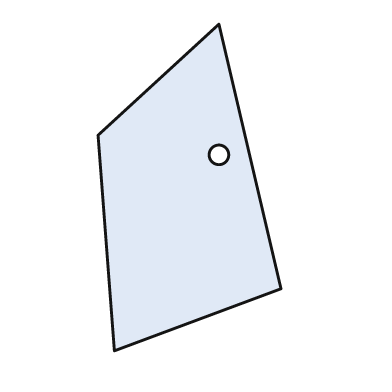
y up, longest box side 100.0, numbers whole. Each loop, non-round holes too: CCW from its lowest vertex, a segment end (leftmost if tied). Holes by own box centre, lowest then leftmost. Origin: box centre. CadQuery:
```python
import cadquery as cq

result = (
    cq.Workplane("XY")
    .moveTo(-23.0, -50.0)
    .lineTo(28.0, -31.0)
    .lineTo(9.0, 50.0)
    .lineTo(-28.0, 16.0)
    .close()
    .moveTo(9.0, 10.0)
    .circle(3.0)
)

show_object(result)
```